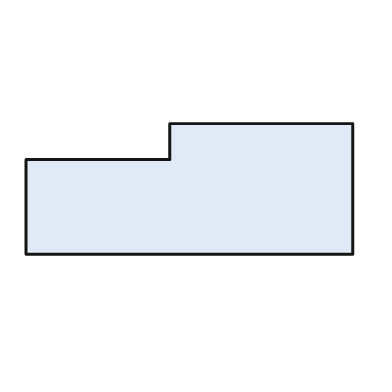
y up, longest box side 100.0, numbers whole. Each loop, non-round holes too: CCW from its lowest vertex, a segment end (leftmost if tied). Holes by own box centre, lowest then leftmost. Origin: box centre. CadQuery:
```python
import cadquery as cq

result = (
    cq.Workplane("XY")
    .moveTo(-50.0, -20.0)
    .lineTo(50.0, -20.0)
    .lineTo(50.0, 20.0)
    .lineTo(-6.0, 20.0)
    .lineTo(-6.0, 9.0)
    .lineTo(-50.0, 9.0)
    .close()
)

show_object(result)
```